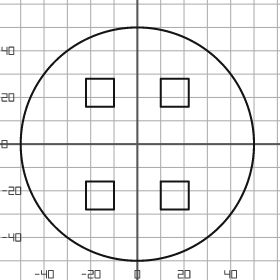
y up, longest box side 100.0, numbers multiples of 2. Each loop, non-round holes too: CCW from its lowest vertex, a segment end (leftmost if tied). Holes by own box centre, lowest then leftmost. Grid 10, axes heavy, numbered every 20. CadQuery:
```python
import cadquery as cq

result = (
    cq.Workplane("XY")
    .moveTo(0.0, 0.0)
    .circle(50.0)
    .moveTo(-22.0, -28.0)
    .lineTo(-10.0, -28.0)
    .lineTo(-10.0, -16.0)
    .lineTo(-22.0, -16.0)
    .close()
    .moveTo(10.0, -28.0)
    .lineTo(22.0, -28.0)
    .lineTo(22.0, -16.0)
    .lineTo(10.0, -16.0)
    .close()
    .moveTo(-22.0, 16.0)
    .lineTo(-10.0, 16.0)
    .lineTo(-10.0, 28.0)
    .lineTo(-22.0, 28.0)
    .close()
    .moveTo(10.0, 16.0)
    .lineTo(22.0, 16.0)
    .lineTo(22.0, 28.0)
    .lineTo(10.0, 28.0)
    .close()
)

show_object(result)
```